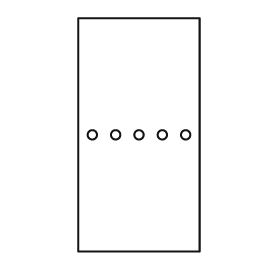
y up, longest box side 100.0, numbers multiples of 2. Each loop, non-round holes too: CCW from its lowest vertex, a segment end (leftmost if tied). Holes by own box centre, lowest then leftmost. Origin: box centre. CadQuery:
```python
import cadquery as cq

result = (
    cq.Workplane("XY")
    .moveTo(-26.0, -50.0)
    .lineTo(26.0, -50.0)
    .lineTo(26.0, 50.0)
    .lineTo(-26.0, 50.0)
    .close()
    .moveTo(-20.0, 0.0)
    .circle(2.0)
    .moveTo(-10.0, 0.0)
    .circle(2.0)
    .moveTo(0.0, 0.0)
    .circle(2.0)
    .moveTo(10.0, 0.0)
    .circle(2.0)
    .moveTo(20.0, 0.0)
    .circle(2.0)
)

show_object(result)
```